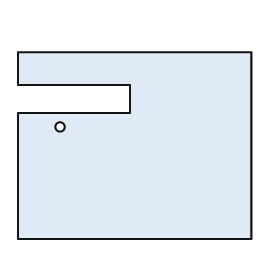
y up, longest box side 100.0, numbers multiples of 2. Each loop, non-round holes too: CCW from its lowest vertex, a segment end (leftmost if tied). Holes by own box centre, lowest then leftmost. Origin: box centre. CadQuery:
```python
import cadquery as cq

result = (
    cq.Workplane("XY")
    .moveTo(-50.0, -40.0)
    .lineTo(50.0, -40.0)
    .lineTo(50.0, 40.0)
    .lineTo(-50.0, 40.0)
    .lineTo(-50.0, 26.0)
    .lineTo(-2.0, 26.0)
    .lineTo(-2.0, 14.0)
    .lineTo(-50.0, 14.0)
    .close()
    .moveTo(-32.0, 8.0)
    .circle(2.0)
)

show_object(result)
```